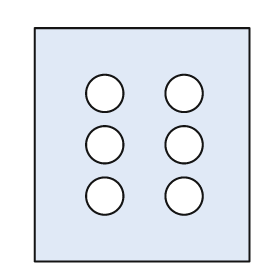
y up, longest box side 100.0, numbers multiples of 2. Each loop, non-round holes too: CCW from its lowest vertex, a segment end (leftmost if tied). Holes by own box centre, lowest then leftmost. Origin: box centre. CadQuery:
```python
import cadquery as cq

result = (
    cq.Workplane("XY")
    .moveTo(-46.0, -50.0)
    .lineTo(46.0, -50.0)
    .lineTo(46.0, 50.0)
    .lineTo(-46.0, 50.0)
    .close()
    .moveTo(-16.0, -22.0)
    .circle(8.0)
    .moveTo(18.0, -22.0)
    .circle(8.0)
    .moveTo(-16.0, 0.0)
    .circle(8.0)
    .moveTo(18.0, 0.0)
    .circle(8.0)
    .moveTo(-16.0, 22.0)
    .circle(8.0)
    .moveTo(18.0, 22.0)
    .circle(8.0)
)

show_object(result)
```